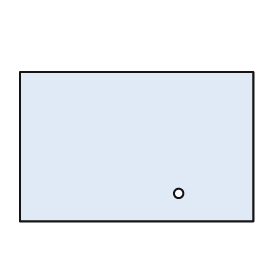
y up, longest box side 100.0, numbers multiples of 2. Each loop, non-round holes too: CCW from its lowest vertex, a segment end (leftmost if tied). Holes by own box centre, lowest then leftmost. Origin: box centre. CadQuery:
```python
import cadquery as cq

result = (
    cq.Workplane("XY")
    .moveTo(-50.0, -32.0)
    .lineTo(50.0, -32.0)
    .lineTo(50.0, 32.0)
    .lineTo(-50.0, 32.0)
    .close()
    .moveTo(18.0, -20.0)
    .circle(2.0)
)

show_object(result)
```